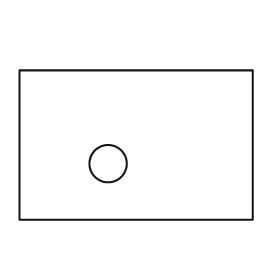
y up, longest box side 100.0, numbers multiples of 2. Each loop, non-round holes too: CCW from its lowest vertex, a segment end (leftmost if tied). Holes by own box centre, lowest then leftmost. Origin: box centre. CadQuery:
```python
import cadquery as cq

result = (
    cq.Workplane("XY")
    .moveTo(-50.0, -32.0)
    .lineTo(50.0, -32.0)
    .lineTo(50.0, 32.0)
    .lineTo(-50.0, 32.0)
    .close()
    .moveTo(-12.0, -8.0)
    .circle(8.0)
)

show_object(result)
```